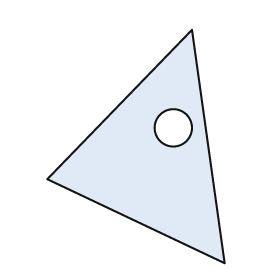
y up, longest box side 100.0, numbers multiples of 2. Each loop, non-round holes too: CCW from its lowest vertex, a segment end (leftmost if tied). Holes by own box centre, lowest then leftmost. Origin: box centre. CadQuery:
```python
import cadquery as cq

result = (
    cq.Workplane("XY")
    .moveTo(38.0, -50.0)
    .lineTo(24.0, 50.0)
    .lineTo(-38.0, -14.0)
    .close()
    .moveTo(16.0, 8.0)
    .circle(8.0)
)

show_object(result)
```